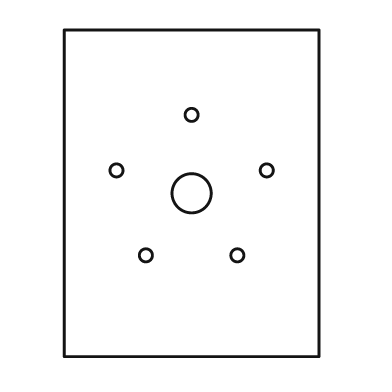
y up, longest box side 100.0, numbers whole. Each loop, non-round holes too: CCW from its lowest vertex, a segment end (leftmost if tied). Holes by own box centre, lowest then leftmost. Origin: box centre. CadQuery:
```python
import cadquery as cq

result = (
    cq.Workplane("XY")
    .moveTo(-39.0, -50.0)
    .lineTo(39.0, -50.0)
    .lineTo(39.0, 50.0)
    .lineTo(-39.0, 50.0)
    .close()
    .moveTo(-14.0, -19.0)
    .circle(2.0)
    .moveTo(14.0, -19.0)
    .circle(2.0)
    .moveTo(0.0, 0.0)
    .circle(6.0)
    .moveTo(-23.0, 7.0)
    .circle(2.0)
    .moveTo(23.0, 7.0)
    .circle(2.0)
    .moveTo(0.0, 24.0)
    .circle(2.0)
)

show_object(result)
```